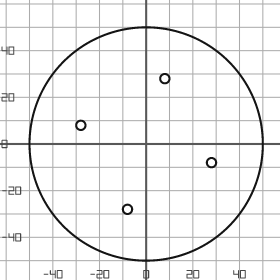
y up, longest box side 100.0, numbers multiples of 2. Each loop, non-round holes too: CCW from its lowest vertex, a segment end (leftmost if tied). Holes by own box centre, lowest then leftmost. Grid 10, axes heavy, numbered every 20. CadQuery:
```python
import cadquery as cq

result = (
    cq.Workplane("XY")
    .moveTo(0.0, 0.0)
    .circle(50.0)
    .moveTo(-8.0, -28.0)
    .circle(2.0)
    .moveTo(28.0, -8.0)
    .circle(2.0)
    .moveTo(-28.0, 8.0)
    .circle(2.0)
    .moveTo(8.0, 28.0)
    .circle(2.0)
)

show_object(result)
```